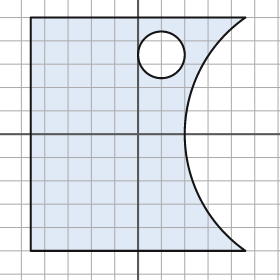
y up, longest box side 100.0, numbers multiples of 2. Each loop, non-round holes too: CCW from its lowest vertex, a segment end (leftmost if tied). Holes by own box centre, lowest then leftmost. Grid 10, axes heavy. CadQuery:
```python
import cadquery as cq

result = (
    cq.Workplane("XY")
    .moveTo(-46.0, -50.0)
    .lineTo(46.0, -50.0)
    .threePointArc((20.0, 0.0), (46.0, 50.0))
    .lineTo(-46.0, 50.0)
    .close()
    .moveTo(10.0, 34.0)
    .circle(10.0)
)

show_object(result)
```